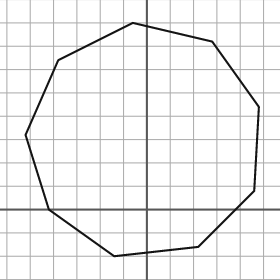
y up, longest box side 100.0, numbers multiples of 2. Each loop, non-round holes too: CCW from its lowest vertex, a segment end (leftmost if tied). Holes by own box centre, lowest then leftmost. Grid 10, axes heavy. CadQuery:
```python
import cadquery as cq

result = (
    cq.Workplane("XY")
    .moveTo(-14.0, -20.0)
    .lineTo(22.0, -16.0)
    .lineTo(46.0, 8.0)
    .lineTo(48.0, 44.0)
    .lineTo(28.0, 72.0)
    .lineTo(-6.0, 80.0)
    .lineTo(-38.0, 64.0)
    .lineTo(-52.0, 32.0)
    .lineTo(-42.0, 0.0)
    .close()
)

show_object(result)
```